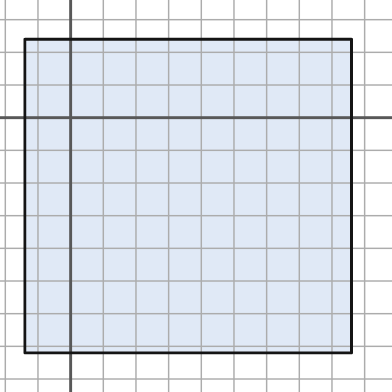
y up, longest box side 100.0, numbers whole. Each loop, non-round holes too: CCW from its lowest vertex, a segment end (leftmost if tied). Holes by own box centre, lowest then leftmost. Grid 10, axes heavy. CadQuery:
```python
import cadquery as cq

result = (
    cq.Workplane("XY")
    .moveTo(-14.0, -72.0)
    .lineTo(86.0, -72.0)
    .lineTo(86.0, 24.0)
    .lineTo(-14.0, 24.0)
    .close()
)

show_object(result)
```